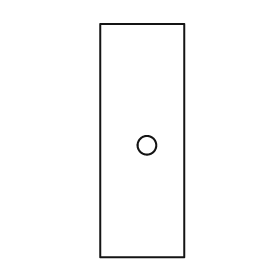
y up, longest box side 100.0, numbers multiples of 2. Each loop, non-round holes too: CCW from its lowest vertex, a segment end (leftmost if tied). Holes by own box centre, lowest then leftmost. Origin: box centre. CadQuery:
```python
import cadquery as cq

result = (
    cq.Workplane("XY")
    .moveTo(-18.0, -50.0)
    .lineTo(18.0, -50.0)
    .lineTo(18.0, 50.0)
    .lineTo(-18.0, 50.0)
    .close()
    .moveTo(2.0, -2.0)
    .circle(4.0)
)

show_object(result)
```